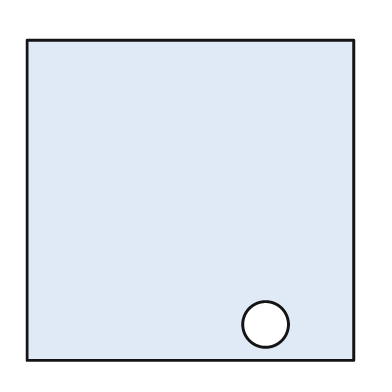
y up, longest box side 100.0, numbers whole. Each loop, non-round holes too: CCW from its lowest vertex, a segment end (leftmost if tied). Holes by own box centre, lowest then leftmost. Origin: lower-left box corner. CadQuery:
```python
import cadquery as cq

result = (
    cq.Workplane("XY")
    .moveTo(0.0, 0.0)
    .lineTo(100.0, 0.0)
    .lineTo(100.0, 98.0)
    .lineTo(0.0, 98.0)
    .close()
    .moveTo(73.0, 11.0)
    .circle(7.0)
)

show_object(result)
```